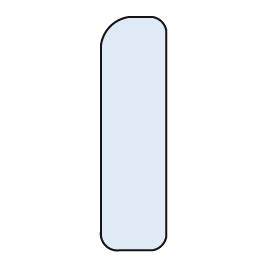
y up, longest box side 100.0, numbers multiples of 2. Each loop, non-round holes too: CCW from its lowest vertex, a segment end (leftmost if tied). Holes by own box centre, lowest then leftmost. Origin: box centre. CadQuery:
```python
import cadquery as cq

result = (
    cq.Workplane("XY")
    .moveTo(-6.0, -50.0)
    .lineTo(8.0, -50.0)
    .threePointArc((12.0, -48.0), (14.0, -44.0))
    .lineTo(14.0, 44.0)
    .threePointArc((12.0, 48.0), (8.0, 50.0))
    .lineTo(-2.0, 50.0)
    .threePointArc((-10.0, 46.0), (-14.0, 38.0))
    .lineTo(-14.0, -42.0)
    .threePointArc((-12.0, -48.0), (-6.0, -50.0))
    .close()
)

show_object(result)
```